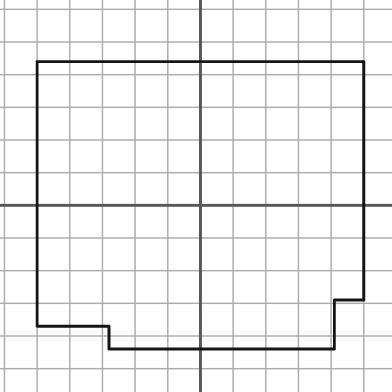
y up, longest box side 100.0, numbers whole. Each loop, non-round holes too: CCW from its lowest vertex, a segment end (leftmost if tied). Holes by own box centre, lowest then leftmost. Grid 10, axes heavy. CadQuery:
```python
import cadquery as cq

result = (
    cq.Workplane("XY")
    .moveTo(-28.0, -44.0)
    .lineTo(41.0, -44.0)
    .lineTo(41.0, -29.0)
    .lineTo(50.0, -29.0)
    .lineTo(50.0, 44.0)
    .lineTo(-50.0, 44.0)
    .lineTo(-50.0, -37.0)
    .lineTo(-28.0, -37.0)
    .close()
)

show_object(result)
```